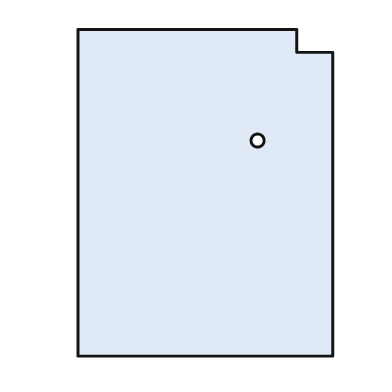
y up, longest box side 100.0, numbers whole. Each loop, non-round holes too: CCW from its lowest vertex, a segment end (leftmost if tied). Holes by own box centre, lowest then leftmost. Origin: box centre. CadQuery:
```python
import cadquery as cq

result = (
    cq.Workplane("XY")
    .moveTo(-39.0, -50.0)
    .lineTo(39.0, -50.0)
    .lineTo(39.0, 43.0)
    .lineTo(28.0, 43.0)
    .lineTo(28.0, 50.0)
    .lineTo(-39.0, 50.0)
    .close()
    .moveTo(16.0, 16.0)
    .circle(2.0)
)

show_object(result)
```